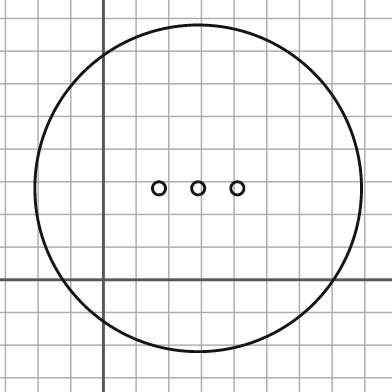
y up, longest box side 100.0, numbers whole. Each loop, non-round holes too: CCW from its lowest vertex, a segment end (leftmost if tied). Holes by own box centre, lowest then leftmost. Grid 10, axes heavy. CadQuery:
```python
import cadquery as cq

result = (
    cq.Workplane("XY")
    .moveTo(29.0, 28.0)
    .circle(50.0)
    .moveTo(17.0, 28.0)
    .circle(2.0)
    .moveTo(29.0, 28.0)
    .circle(2.0)
    .moveTo(41.0, 28.0)
    .circle(2.0)
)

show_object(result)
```